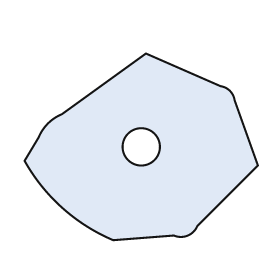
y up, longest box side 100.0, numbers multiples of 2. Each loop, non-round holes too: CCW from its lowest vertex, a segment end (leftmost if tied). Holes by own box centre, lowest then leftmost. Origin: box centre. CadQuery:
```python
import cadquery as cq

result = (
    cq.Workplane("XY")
    .moveTo(-12.0, -40.0)
    .lineTo(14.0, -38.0)
    .threePointArc((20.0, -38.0), (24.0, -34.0))
    .lineTo(50.0, -8.0)
    .lineTo(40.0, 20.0)
    .threePointArc((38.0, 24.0), (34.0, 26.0))
    .lineTo(2.0, 40.0)
    .lineTo(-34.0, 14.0)
    .threePointArc((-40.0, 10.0), (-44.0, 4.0))
    .lineTo(-50.0, -6.0)
    .threePointArc((-34.0, -26.0), (-12.0, -40.0))
    .close()
    .moveTo(0.0, 0.0)
    .circle(8.0)
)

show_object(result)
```